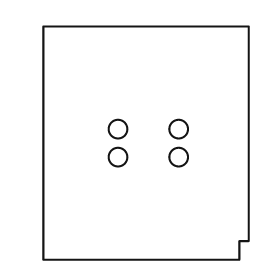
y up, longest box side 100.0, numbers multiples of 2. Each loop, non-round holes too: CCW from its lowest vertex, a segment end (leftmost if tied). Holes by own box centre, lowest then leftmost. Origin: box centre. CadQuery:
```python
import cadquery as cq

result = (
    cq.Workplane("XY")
    .moveTo(-44.0, -50.0)
    .lineTo(40.0, -50.0)
    .lineTo(40.0, -42.0)
    .lineTo(44.0, -42.0)
    .lineTo(44.0, 50.0)
    .lineTo(-44.0, 50.0)
    .close()
    .moveTo(-12.0, -6.0)
    .circle(4.0)
    .moveTo(14.0, -6.0)
    .circle(4.0)
    .moveTo(-12.0, 6.0)
    .circle(4.0)
    .moveTo(14.0, 6.0)
    .circle(4.0)
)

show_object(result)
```